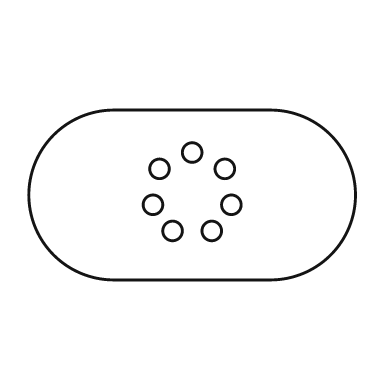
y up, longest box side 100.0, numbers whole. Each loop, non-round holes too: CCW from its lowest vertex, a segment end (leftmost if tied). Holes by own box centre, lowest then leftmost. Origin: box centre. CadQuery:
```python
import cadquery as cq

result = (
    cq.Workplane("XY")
    .moveTo(-24.0, -26.0)
    .lineTo(24.0, -26.0)
    .threePointArc((50.0, 0.0), (24.0, 26.0))
    .lineTo(-24.0, 26.0)
    .threePointArc((-50.0, 0.0), (-24.0, -26.0))
    .close()
    .moveTo(-6.0, -11.0)
    .circle(3.0)
    .moveTo(6.0, -11.0)
    .circle(3.0)
    .moveTo(-12.0, -3.0)
    .circle(3.0)
    .moveTo(12.0, -3.0)
    .circle(3.0)
    .moveTo(-10.0, 8.0)
    .circle(3.0)
    .moveTo(10.0, 8.0)
    .circle(3.0)
    .moveTo(0.0, 13.0)
    .circle(3.0)
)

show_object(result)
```